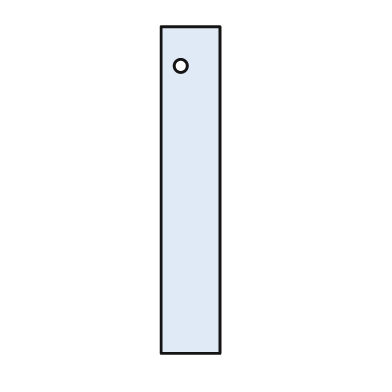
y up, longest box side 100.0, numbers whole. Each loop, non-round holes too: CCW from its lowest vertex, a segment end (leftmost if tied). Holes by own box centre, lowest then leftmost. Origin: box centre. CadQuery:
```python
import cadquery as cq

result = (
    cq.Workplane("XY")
    .moveTo(-9.0, -50.0)
    .lineTo(9.0, -50.0)
    .lineTo(9.0, 50.0)
    .lineTo(-9.0, 50.0)
    .close()
    .moveTo(-3.0, 38.0)
    .circle(2.0)
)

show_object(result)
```